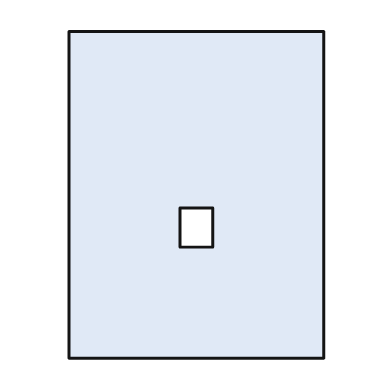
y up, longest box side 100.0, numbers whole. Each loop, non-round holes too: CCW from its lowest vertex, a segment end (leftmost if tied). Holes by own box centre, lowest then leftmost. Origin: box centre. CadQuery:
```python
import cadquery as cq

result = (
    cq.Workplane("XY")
    .moveTo(-39.0, -50.0)
    .lineTo(39.0, -50.0)
    .lineTo(39.0, 50.0)
    .lineTo(-39.0, 50.0)
    .close()
    .moveTo(-5.0, -16.0)
    .lineTo(5.0, -16.0)
    .lineTo(5.0, -4.0)
    .lineTo(-5.0, -4.0)
    .close()
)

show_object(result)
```